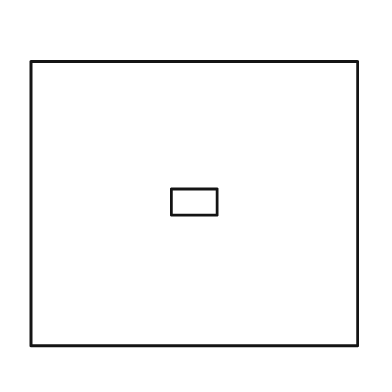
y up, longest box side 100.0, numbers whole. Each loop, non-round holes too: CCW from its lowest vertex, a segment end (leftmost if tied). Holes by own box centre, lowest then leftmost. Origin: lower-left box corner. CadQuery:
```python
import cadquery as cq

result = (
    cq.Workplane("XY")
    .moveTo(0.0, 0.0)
    .lineTo(100.0, 0.0)
    .lineTo(100.0, 87.0)
    .lineTo(0.0, 87.0)
    .close()
    .moveTo(43.0, 40.0)
    .lineTo(57.0, 40.0)
    .lineTo(57.0, 48.0)
    .lineTo(43.0, 48.0)
    .close()
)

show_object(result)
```